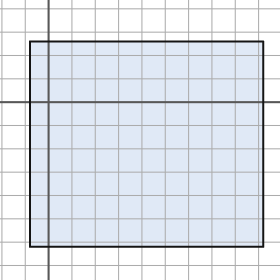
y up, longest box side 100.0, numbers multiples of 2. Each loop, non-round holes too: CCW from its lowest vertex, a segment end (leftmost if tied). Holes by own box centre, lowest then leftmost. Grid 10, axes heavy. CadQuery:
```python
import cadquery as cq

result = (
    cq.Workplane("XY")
    .moveTo(-8.0, -62.0)
    .lineTo(92.0, -62.0)
    .lineTo(92.0, 26.0)
    .lineTo(-8.0, 26.0)
    .close()
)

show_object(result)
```